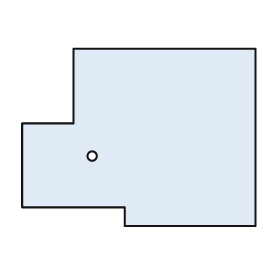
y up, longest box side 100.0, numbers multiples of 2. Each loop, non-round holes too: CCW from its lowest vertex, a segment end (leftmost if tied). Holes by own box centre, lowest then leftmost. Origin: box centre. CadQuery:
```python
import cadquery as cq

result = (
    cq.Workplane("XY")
    .moveTo(-6.0, -38.0)
    .lineTo(50.0, -38.0)
    .lineTo(50.0, 38.0)
    .lineTo(-28.0, 38.0)
    .lineTo(-28.0, 6.0)
    .lineTo(-50.0, 6.0)
    .lineTo(-50.0, -30.0)
    .lineTo(-6.0, -30.0)
    .close()
    .moveTo(-20.0, -8.0)
    .circle(2.0)
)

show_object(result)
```